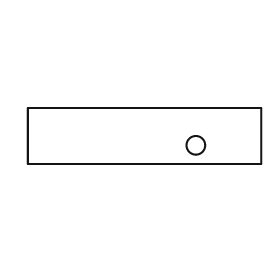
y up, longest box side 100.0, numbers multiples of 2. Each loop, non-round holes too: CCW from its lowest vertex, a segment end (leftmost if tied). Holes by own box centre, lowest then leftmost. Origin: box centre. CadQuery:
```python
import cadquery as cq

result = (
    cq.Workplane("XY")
    .moveTo(-50.0, -12.0)
    .lineTo(50.0, -12.0)
    .lineTo(50.0, 12.0)
    .lineTo(-50.0, 12.0)
    .close()
    .moveTo(22.0, -4.0)
    .circle(4.0)
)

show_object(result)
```